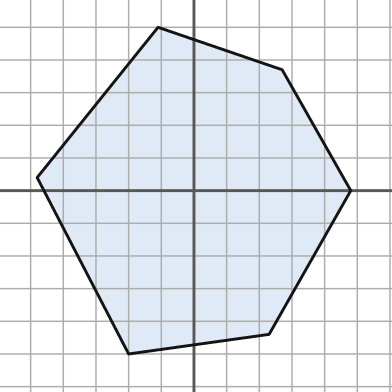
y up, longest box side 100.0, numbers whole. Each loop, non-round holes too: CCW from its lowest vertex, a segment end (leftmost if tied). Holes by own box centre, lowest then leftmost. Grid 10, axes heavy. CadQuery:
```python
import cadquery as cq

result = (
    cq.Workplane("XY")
    .moveTo(-20.0, -50.0)
    .lineTo(23.0, -44.0)
    .lineTo(48.0, 0.0)
    .lineTo(27.0, 37.0)
    .lineTo(-11.0, 50.0)
    .lineTo(-48.0, 4.0)
    .close()
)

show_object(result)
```